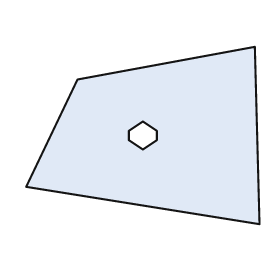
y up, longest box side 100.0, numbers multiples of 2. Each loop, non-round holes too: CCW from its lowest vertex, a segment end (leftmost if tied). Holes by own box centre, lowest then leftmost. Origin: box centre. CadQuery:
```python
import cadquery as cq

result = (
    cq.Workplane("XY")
    .moveTo(50.0, -38.0)
    .lineTo(48.0, 38.0)
    .lineTo(-28.0, 24.0)
    .lineTo(-50.0, -22.0)
    .close()
    .moveTo(0.0, -6.0)
    .lineTo(6.0, -2.0)
    .lineTo(6.0, 2.0)
    .lineTo(0.0, 6.0)
    .lineTo(-6.0, 2.0)
    .lineTo(-6.0, -2.0)
    .close()
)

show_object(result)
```